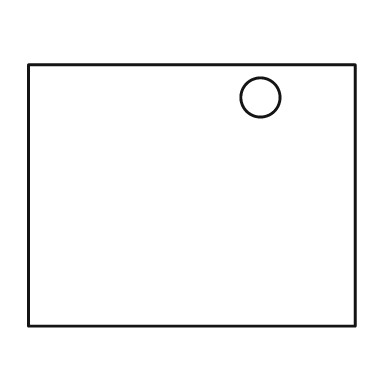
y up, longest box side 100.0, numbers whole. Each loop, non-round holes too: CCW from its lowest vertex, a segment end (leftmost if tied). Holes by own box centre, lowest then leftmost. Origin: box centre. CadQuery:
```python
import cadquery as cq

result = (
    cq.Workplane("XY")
    .moveTo(-50.0, -40.0)
    .lineTo(50.0, -40.0)
    .lineTo(50.0, 40.0)
    .lineTo(-50.0, 40.0)
    .close()
    .moveTo(21.0, 30.0)
    .circle(6.0)
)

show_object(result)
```